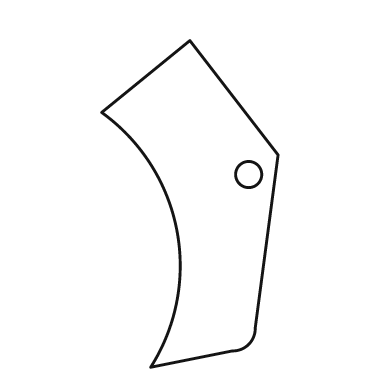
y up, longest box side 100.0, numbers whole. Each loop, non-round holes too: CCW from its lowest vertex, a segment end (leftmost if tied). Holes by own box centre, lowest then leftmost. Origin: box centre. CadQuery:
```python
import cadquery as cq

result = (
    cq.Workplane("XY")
    .moveTo(-12.0, -50.0)
    .lineTo(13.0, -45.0)
    .threePointArc((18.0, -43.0), (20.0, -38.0))
    .lineTo(27.0, 15.0)
    .lineTo(0.0, 50.0)
    .lineTo(-27.0, 28.0)
    .threePointArc((-4.0, -8.0), (-12.0, -50.0))
    .close()
    .moveTo(18.0, 9.0)
    .circle(4.0)
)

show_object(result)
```